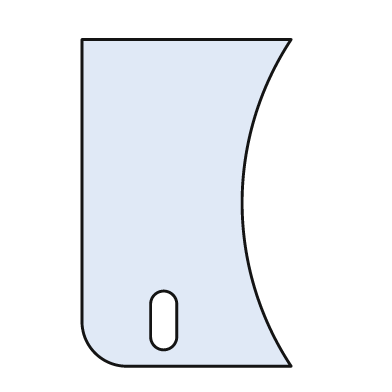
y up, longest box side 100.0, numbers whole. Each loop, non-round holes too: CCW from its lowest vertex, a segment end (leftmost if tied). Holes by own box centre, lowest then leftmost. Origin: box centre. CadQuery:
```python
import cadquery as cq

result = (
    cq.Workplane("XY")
    .moveTo(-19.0, -50.0)
    .lineTo(32.0, -50.0)
    .threePointArc((17.0, 0.0), (32.0, 50.0))
    .lineTo(-32.0, 50.0)
    .lineTo(-32.0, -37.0)
    .threePointArc((-28.0, -46.0), (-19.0, -50.0))
    .close()
    .moveTo(-11.0, -41.0)
    .threePointArc((-7.0, -45.0), (-3.0, -41.0))
    .lineTo(-3.0, -31.0)
    .threePointArc((-7.0, -27.0), (-11.0, -31.0))
    .close()
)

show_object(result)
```